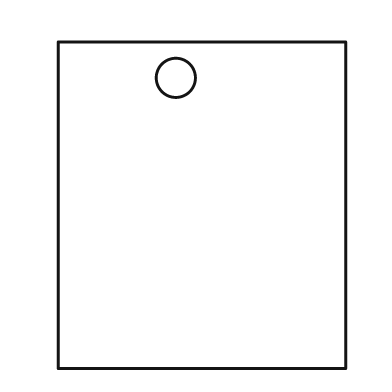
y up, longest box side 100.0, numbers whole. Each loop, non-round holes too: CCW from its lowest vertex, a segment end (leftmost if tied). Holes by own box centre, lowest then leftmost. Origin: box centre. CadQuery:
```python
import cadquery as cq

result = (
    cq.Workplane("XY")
    .moveTo(-44.0, -50.0)
    .lineTo(44.0, -50.0)
    .lineTo(44.0, 50.0)
    .lineTo(-44.0, 50.0)
    .close()
    .moveTo(-8.0, 39.0)
    .circle(6.0)
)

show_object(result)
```